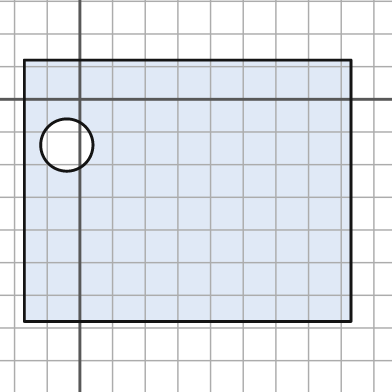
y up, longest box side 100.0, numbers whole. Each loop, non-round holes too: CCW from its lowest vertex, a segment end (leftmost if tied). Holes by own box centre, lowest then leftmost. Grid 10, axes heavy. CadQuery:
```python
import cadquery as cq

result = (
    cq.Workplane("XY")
    .moveTo(-17.0, -68.0)
    .lineTo(83.0, -68.0)
    .lineTo(83.0, 12.0)
    .lineTo(-17.0, 12.0)
    .close()
    .moveTo(-4.0, -14.0)
    .circle(8.0)
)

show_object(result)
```